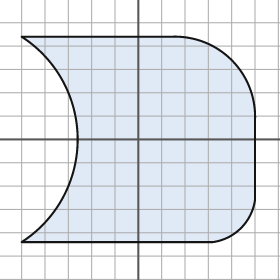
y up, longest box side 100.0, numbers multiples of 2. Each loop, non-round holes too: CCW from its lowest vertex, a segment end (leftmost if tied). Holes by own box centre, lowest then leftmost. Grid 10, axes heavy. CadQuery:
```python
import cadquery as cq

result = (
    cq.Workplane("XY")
    .moveTo(-50.0, -44.0)
    .lineTo(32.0, -44.0)
    .threePointArc((44.0, -38.0), (50.0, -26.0))
    .lineTo(50.0, 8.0)
    .threePointArc((40.0, 34.0), (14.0, 44.0))
    .lineTo(-50.0, 44.0)
    .threePointArc((-26.0, 0.0), (-50.0, -44.0))
    .close()
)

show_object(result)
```